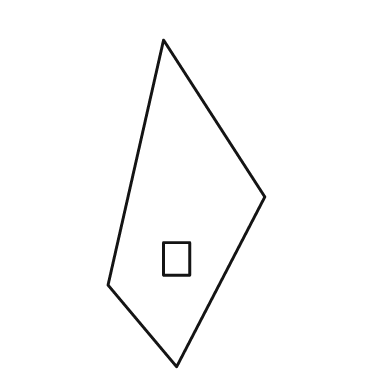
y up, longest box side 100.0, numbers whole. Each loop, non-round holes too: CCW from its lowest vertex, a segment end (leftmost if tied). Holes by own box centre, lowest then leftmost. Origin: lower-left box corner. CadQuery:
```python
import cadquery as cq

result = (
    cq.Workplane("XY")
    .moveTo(21.0, 0.0)
    .lineTo(48.0, 52.0)
    .lineTo(17.0, 100.0)
    .lineTo(0.0, 25.0)
    .close()
    .moveTo(17.0, 28.0)
    .lineTo(25.0, 28.0)
    .lineTo(25.0, 38.0)
    .lineTo(17.0, 38.0)
    .close()
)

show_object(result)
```